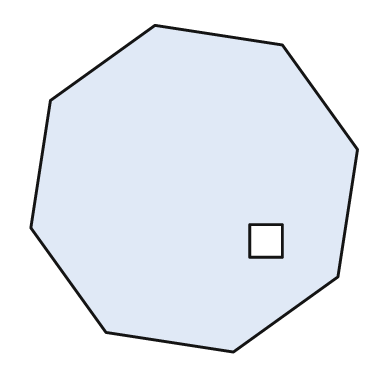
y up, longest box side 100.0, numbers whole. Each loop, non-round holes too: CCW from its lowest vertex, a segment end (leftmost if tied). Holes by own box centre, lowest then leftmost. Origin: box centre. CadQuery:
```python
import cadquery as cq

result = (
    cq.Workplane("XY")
    .moveTo(12.0, -50.0)
    .lineTo(44.0, -27.0)
    .lineTo(50.0, 12.0)
    .lineTo(27.0, 44.0)
    .lineTo(-12.0, 50.0)
    .lineTo(-44.0, 27.0)
    .lineTo(-50.0, -12.0)
    .lineTo(-27.0, -44.0)
    .close()
    .moveTo(17.0, -21.0)
    .lineTo(27.0, -21.0)
    .lineTo(27.0, -11.0)
    .lineTo(17.0, -11.0)
    .close()
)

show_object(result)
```